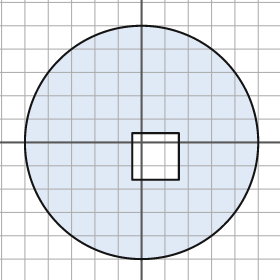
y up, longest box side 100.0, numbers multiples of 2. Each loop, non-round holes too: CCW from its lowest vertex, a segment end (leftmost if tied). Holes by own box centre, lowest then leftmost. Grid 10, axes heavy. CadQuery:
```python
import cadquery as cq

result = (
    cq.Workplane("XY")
    .moveTo(0.0, 0.0)
    .circle(50.0)
    .moveTo(-4.0, -16.0)
    .lineTo(16.0, -16.0)
    .lineTo(16.0, 4.0)
    .lineTo(-4.0, 4.0)
    .close()
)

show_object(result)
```